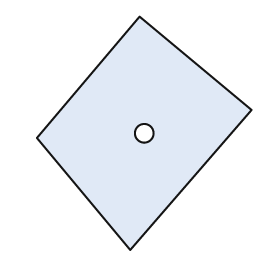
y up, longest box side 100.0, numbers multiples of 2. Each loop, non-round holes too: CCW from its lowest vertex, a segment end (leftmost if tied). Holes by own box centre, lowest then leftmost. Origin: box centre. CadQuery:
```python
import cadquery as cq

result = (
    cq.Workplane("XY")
    .moveTo(-6.0, -50.0)
    .lineTo(46.0, 10.0)
    .lineTo(-2.0, 50.0)
    .lineTo(-46.0, -2.0)
    .close()
    .moveTo(0.0, 0.0)
    .circle(4.0)
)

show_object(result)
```